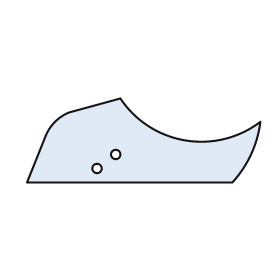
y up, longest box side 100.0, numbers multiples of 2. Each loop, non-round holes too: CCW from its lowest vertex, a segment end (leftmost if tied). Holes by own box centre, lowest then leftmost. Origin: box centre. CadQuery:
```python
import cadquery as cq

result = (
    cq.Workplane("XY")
    .moveTo(-50.0, -18.0)
    .lineTo(38.0, -18.0)
    .threePointArc((46.0, -6.0), (50.0, 8.0))
    .threePointArc((18.0, 0.0), (-10.0, 18.0))
    .lineTo(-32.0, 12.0)
    .threePointArc((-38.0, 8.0), (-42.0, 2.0))
    .close()
    .moveTo(-20.0, -12.0)
    .circle(2.0)
    .moveTo(-12.0, -6.0)
    .circle(2.0)
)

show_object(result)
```